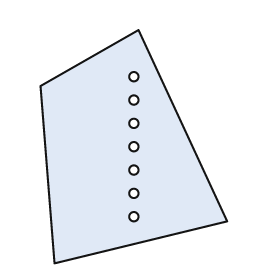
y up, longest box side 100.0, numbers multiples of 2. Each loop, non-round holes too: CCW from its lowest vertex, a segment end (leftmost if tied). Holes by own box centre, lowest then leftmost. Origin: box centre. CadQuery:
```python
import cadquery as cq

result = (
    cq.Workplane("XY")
    .moveTo(-34.0, -50.0)
    .lineTo(40.0, -32.0)
    .lineTo(2.0, 50.0)
    .lineTo(-40.0, 26.0)
    .close()
    .moveTo(0.0, -30.0)
    .circle(2.0)
    .moveTo(0.0, -20.0)
    .circle(2.0)
    .moveTo(0.0, -10.0)
    .circle(2.0)
    .moveTo(0.0, 0.0)
    .circle(2.0)
    .moveTo(0.0, 10.0)
    .circle(2.0)
    .moveTo(0.0, 20.0)
    .circle(2.0)
    .moveTo(0.0, 30.0)
    .circle(2.0)
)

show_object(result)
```